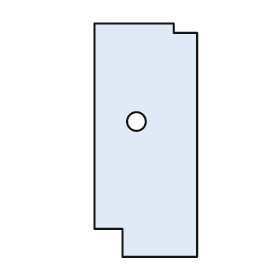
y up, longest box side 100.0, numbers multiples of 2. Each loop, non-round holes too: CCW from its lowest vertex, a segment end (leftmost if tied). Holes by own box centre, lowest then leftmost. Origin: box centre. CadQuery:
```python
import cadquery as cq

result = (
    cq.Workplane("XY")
    .moveTo(-10.0, -50.0)
    .lineTo(22.0, -50.0)
    .lineTo(22.0, 46.0)
    .lineTo(12.0, 46.0)
    .lineTo(12.0, 50.0)
    .lineTo(-22.0, 50.0)
    .lineTo(-22.0, -38.0)
    .lineTo(-10.0, -38.0)
    .close()
    .moveTo(-4.0, 8.0)
    .circle(4.0)
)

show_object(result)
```